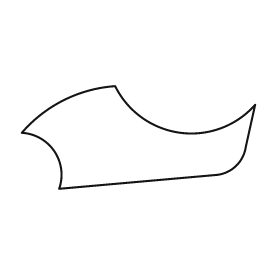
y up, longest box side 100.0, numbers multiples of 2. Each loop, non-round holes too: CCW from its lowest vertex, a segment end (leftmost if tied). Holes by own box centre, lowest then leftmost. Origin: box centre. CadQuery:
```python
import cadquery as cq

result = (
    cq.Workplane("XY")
    .moveTo(-34.0, -22.0)
    .lineTo(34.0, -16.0)
    .threePointArc((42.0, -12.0), (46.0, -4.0))
    .lineTo(50.0, 14.0)
    .threePointArc((18.0, 2.0), (-10.0, 22.0))
    .threePointArc((-32.0, 16.0), (-50.0, 2.0))
    .threePointArc((-36.0, -6.0), (-34.0, -22.0))
    .close()
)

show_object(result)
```